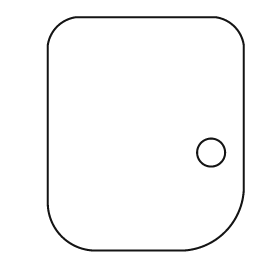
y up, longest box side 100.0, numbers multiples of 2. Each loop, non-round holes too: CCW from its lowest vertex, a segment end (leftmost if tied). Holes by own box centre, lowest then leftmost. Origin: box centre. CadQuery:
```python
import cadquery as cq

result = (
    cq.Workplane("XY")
    .moveTo(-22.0, -50.0)
    .lineTo(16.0, -50.0)
    .threePointArc((34.0, -42.0), (42.0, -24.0))
    .lineTo(42.0, 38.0)
    .threePointArc((38.0, 46.0), (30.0, 50.0))
    .lineTo(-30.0, 50.0)
    .threePointArc((-38.0, 46.0), (-42.0, 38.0))
    .lineTo(-42.0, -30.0)
    .threePointArc((-36.0, -44.0), (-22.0, -50.0))
    .close()
    .moveTo(28.0, -8.0)
    .circle(6.0)
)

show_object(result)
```